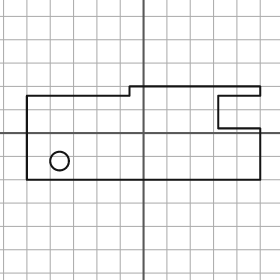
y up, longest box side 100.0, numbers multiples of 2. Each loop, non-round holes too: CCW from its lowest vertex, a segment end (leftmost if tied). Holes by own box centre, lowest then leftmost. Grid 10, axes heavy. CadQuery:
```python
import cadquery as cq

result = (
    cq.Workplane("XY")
    .moveTo(-50.0, -20.0)
    .lineTo(50.0, -20.0)
    .lineTo(50.0, 2.0)
    .lineTo(32.0, 2.0)
    .lineTo(32.0, 16.0)
    .lineTo(50.0, 16.0)
    .lineTo(50.0, 20.0)
    .lineTo(-6.0, 20.0)
    .lineTo(-6.0, 16.0)
    .lineTo(-50.0, 16.0)
    .close()
    .moveTo(-36.0, -12.0)
    .circle(4.0)
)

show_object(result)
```